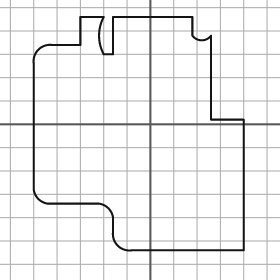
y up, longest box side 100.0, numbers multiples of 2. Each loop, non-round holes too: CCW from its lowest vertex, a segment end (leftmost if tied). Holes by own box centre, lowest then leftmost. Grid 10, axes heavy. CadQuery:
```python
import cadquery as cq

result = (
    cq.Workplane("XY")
    .moveTo(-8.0, -54.0)
    .lineTo(40.0, -54.0)
    .lineTo(40.0, 2.0)
    .lineTo(26.0, 2.0)
    .lineTo(26.0, 38.0)
    .threePointArc((22.0, 36.0), (18.0, 38.0))
    .lineTo(18.0, 46.0)
    .lineTo(-16.0, 46.0)
    .lineTo(-16.0, 30.0)
    .lineTo(-20.0, 30.0)
    .threePointArc((-22.0, 38.0), (-20.0, 46.0))
    .lineTo(-30.0, 46.0)
    .lineTo(-30.0, 34.0)
    .lineTo(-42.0, 34.0)
    .threePointArc((-48.0, 32.0), (-50.0, 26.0))
    .lineTo(-50.0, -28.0)
    .threePointArc((-48.0, -32.0), (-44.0, -34.0))
    .lineTo(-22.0, -34.0)
    .threePointArc((-18.0, -36.0), (-16.0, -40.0))
    .lineTo(-16.0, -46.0)
    .threePointArc((-14.0, -52.0), (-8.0, -54.0))
    .close()
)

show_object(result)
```